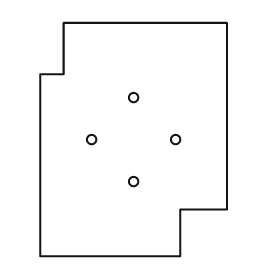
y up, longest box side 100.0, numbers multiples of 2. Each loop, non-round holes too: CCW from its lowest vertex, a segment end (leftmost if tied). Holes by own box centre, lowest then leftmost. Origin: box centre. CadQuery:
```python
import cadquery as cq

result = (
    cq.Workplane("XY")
    .moveTo(-40.0, -50.0)
    .lineTo(20.0, -50.0)
    .lineTo(20.0, -30.0)
    .lineTo(40.0, -30.0)
    .lineTo(40.0, 50.0)
    .lineTo(-30.0, 50.0)
    .lineTo(-30.0, 28.0)
    .lineTo(-40.0, 28.0)
    .close()
    .moveTo(0.0, -18.0)
    .circle(2.0)
    .moveTo(-18.0, 0.0)
    .circle(2.0)
    .moveTo(18.0, 0.0)
    .circle(2.0)
    .moveTo(0.0, 18.0)
    .circle(2.0)
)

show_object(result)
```